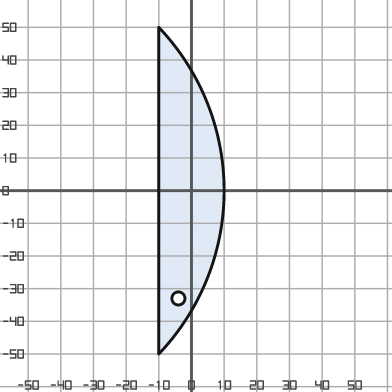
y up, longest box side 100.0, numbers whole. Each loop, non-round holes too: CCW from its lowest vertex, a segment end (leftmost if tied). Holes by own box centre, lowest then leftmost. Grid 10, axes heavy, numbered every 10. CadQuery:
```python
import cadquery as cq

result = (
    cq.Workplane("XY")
    .moveTo(-10.0, -50.0)
    .threePointArc((10.0, 0.0), (-10.0, 50.0))
    .close()
    .moveTo(-4.0, -33.0)
    .circle(2.0)
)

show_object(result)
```